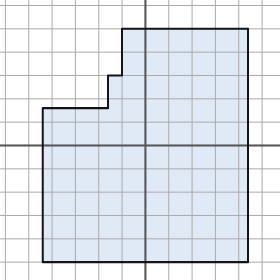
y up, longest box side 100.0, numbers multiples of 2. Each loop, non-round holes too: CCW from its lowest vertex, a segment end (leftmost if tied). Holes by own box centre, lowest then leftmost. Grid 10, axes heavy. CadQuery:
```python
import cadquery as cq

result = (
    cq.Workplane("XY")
    .moveTo(-44.0, -50.0)
    .lineTo(44.0, -50.0)
    .lineTo(44.0, 50.0)
    .lineTo(-10.0, 50.0)
    .lineTo(-10.0, 30.0)
    .lineTo(-16.0, 30.0)
    .lineTo(-16.0, 16.0)
    .lineTo(-44.0, 16.0)
    .close()
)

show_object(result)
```